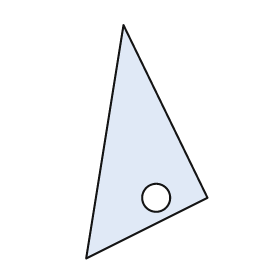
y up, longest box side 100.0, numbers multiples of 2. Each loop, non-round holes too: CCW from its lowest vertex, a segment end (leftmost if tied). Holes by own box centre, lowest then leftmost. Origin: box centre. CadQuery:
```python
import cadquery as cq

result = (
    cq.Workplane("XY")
    .moveTo(-26.0, -50.0)
    .lineTo(26.0, -24.0)
    .lineTo(-10.0, 50.0)
    .close()
    .moveTo(4.0, -24.0)
    .circle(6.0)
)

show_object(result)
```